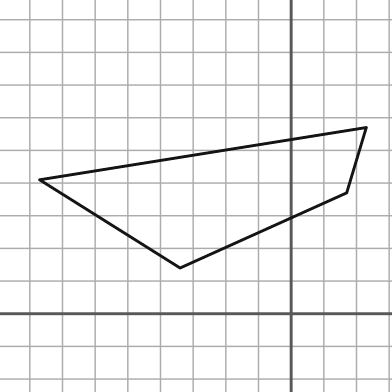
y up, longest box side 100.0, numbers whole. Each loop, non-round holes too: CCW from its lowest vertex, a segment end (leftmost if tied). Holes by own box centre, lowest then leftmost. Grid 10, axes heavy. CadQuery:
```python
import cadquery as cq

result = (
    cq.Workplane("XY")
    .moveTo(-34.0, 14.0)
    .lineTo(17.0, 37.0)
    .lineTo(23.0, 57.0)
    .lineTo(-77.0, 41.0)
    .close()
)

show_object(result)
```